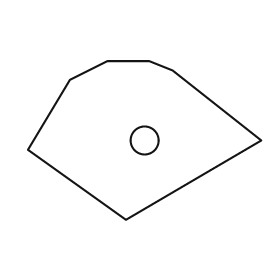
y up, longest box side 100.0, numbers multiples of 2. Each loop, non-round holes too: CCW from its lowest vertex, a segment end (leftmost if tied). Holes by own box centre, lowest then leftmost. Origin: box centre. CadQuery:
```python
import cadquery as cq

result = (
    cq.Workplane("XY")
    .moveTo(-8.0, -34.0)
    .lineTo(50.0, 0.0)
    .lineTo(12.0, 30.0)
    .lineTo(2.0, 34.0)
    .lineTo(-16.0, 34.0)
    .lineTo(-32.0, 26.0)
    .lineTo(-50.0, -4.0)
    .close()
    .moveTo(0.0, 0.0)
    .circle(6.0)
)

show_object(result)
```